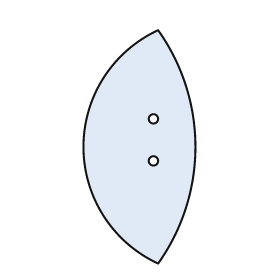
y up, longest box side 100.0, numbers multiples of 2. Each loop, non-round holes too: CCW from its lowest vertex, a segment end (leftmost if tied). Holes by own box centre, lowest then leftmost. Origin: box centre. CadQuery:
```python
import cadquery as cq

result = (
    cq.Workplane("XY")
    .moveTo(8.0, -50.0)
    .threePointArc((24.0, 0.0), (8.0, 50.0))
    .threePointArc((-24.0, 0.0), (8.0, -50.0))
    .close()
    .moveTo(6.0, -6.0)
    .circle(2.0)
    .moveTo(6.0, 12.0)
    .circle(2.0)
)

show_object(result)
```